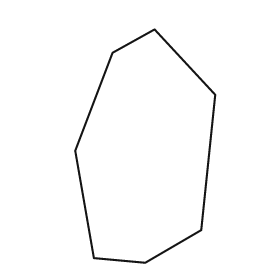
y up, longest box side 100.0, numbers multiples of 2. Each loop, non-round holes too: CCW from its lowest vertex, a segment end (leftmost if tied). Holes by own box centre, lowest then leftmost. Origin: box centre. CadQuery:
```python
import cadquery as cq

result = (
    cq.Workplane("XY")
    .moveTo(0.0, -50.0)
    .lineTo(24.0, -36.0)
    .lineTo(30.0, 22.0)
    .lineTo(4.0, 50.0)
    .lineTo(-14.0, 40.0)
    .lineTo(-30.0, -2.0)
    .lineTo(-22.0, -48.0)
    .close()
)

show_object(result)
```